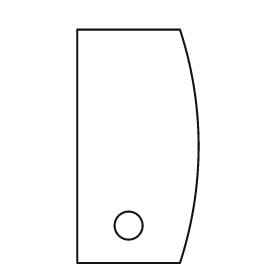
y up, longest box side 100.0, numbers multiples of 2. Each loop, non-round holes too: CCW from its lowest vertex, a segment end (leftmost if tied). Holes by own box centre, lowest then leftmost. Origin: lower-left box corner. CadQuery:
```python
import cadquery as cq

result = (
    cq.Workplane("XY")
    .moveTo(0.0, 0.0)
    .lineTo(44.0, 0.0)
    .threePointArc((52.0, 50.0), (44.0, 100.0))
    .lineTo(0.0, 100.0)
    .close()
    .moveTo(22.0, 16.0)
    .circle(6.0)
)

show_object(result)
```